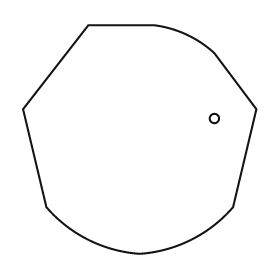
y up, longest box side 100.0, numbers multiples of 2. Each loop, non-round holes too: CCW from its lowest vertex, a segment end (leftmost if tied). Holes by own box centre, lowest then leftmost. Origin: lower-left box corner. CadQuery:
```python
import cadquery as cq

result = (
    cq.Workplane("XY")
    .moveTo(50.0, 0.0)
    .threePointArc((72.0, 6.0), (90.0, 20.0))
    .lineTo(100.0, 62.0)
    .lineTo(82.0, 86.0)
    .threePointArc((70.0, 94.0), (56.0, 98.0))
    .lineTo(28.0, 98.0)
    .lineTo(0.0, 62.0)
    .lineTo(10.0, 20.0)
    .threePointArc((28.0, 6.0), (50.0, 0.0))
    .close()
    .moveTo(82.0, 58.0)
    .circle(2.0)
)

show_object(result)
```